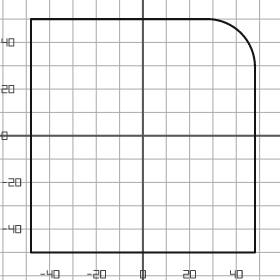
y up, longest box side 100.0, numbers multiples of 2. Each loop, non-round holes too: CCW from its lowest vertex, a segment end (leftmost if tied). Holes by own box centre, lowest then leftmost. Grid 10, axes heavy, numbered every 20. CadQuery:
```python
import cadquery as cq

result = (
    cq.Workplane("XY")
    .moveTo(-48.0, -50.0)
    .lineTo(48.0, -50.0)
    .lineTo(48.0, 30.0)
    .threePointArc((42.0, 44.0), (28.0, 50.0))
    .lineTo(-48.0, 50.0)
    .close()
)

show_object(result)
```